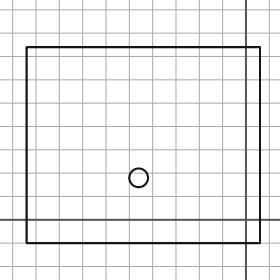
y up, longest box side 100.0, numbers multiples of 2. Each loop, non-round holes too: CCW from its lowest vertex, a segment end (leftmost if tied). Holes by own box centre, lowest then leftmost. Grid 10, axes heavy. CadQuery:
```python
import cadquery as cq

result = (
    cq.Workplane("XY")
    .moveTo(-94.0, -10.0)
    .lineTo(6.0, -10.0)
    .lineTo(6.0, 74.0)
    .lineTo(-94.0, 74.0)
    .close()
    .moveTo(-46.0, 18.0)
    .circle(4.0)
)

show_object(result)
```